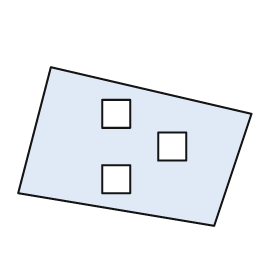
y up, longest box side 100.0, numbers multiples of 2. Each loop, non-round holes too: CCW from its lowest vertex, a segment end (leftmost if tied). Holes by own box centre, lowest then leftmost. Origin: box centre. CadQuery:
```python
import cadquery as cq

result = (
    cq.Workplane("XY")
    .moveTo(34.0, -34.0)
    .lineTo(50.0, 14.0)
    .lineTo(-36.0, 34.0)
    .lineTo(-50.0, -20.0)
    .close()
    .moveTo(-14.0, -20.0)
    .lineTo(-2.0, -20.0)
    .lineTo(-2.0, -8.0)
    .lineTo(-14.0, -8.0)
    .close()
    .moveTo(10.0, -6.0)
    .lineTo(22.0, -6.0)
    .lineTo(22.0, 6.0)
    .lineTo(10.0, 6.0)
    .close()
    .moveTo(-14.0, 8.0)
    .lineTo(-2.0, 8.0)
    .lineTo(-2.0, 20.0)
    .lineTo(-14.0, 20.0)
    .close()
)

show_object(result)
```